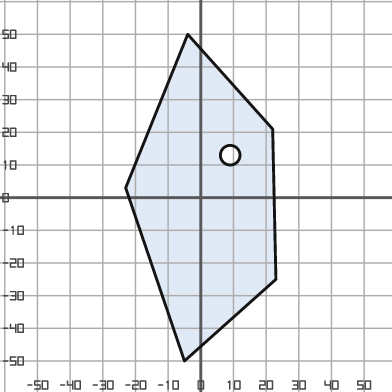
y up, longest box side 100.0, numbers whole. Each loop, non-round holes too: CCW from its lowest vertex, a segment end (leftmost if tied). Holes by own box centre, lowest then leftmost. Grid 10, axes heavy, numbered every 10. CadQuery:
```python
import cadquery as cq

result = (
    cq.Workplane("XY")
    .moveTo(-5.0, -50.0)
    .lineTo(23.0, -25.0)
    .lineTo(22.0, 21.0)
    .lineTo(-4.0, 50.0)
    .lineTo(-23.0, 3.0)
    .close()
    .moveTo(9.0, 13.0)
    .circle(3.0)
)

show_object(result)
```